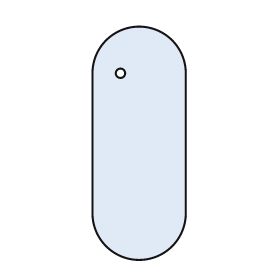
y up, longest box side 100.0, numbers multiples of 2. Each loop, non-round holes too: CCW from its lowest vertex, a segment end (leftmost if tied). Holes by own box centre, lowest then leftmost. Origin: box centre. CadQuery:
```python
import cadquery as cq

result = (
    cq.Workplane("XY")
    .moveTo(-20.0, -30.0)
    .threePointArc((0.0, -50.0), (20.0, -30.0))
    .lineTo(20.0, 30.0)
    .threePointArc((0.0, 50.0), (-20.0, 30.0))
    .close()
    .moveTo(-8.0, 30.0)
    .circle(2.0)
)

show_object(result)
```